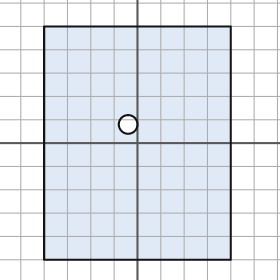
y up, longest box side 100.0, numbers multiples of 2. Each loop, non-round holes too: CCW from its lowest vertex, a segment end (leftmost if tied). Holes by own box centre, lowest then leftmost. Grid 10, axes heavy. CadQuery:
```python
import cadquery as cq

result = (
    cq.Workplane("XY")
    .moveTo(-40.0, -50.0)
    .lineTo(40.0, -50.0)
    .lineTo(40.0, 50.0)
    .lineTo(-40.0, 50.0)
    .close()
    .moveTo(-4.0, 8.0)
    .circle(4.0)
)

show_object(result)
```